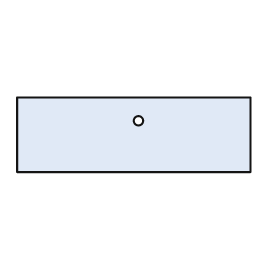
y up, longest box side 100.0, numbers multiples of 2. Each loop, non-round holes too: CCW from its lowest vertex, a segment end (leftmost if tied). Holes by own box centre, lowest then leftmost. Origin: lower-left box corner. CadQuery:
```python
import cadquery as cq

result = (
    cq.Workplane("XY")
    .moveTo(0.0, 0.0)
    .lineTo(100.0, 0.0)
    .lineTo(100.0, 32.0)
    .lineTo(0.0, 32.0)
    .close()
    .moveTo(52.0, 22.0)
    .circle(2.0)
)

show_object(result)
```